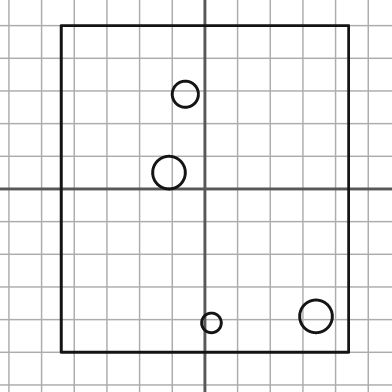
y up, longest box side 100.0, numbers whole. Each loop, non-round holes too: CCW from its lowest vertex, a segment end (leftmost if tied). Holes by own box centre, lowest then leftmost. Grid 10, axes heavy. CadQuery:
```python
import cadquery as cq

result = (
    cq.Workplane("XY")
    .moveTo(-44.0, -50.0)
    .lineTo(44.0, -50.0)
    .lineTo(44.0, 50.0)
    .lineTo(-44.0, 50.0)
    .close()
    .moveTo(2.0, -41.0)
    .circle(3.0)
    .moveTo(34.0, -39.0)
    .circle(5.0)
    .moveTo(-11.0, 5.0)
    .circle(5.0)
    .moveTo(-6.0, 29.0)
    .circle(4.0)
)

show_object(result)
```